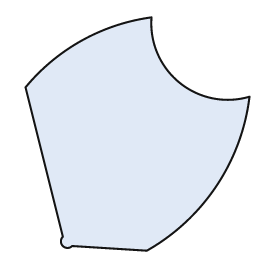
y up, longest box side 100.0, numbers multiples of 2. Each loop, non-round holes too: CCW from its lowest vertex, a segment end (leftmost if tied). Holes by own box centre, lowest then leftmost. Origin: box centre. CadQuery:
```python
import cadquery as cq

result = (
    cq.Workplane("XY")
    .moveTo(4.0, -50.0)
    .threePointArc((34.0, -22.0), (48.0, 16.0))
    .threePointArc((18.0, 22.0), (6.0, 50.0))
    .threePointArc((-24.0, 40.0), (-48.0, 20.0))
    .lineTo(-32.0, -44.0)
    .threePointArc((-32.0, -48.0), (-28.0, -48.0))
    .close()
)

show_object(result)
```